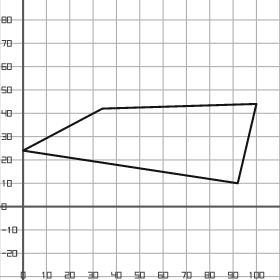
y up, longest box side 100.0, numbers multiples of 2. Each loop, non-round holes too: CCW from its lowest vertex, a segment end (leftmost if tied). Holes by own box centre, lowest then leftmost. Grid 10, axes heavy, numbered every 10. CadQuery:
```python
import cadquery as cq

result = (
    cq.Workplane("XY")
    .moveTo(92.0, 10.0)
    .lineTo(100.0, 44.0)
    .lineTo(34.0, 42.0)
    .lineTo(0.0, 24.0)
    .close()
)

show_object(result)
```